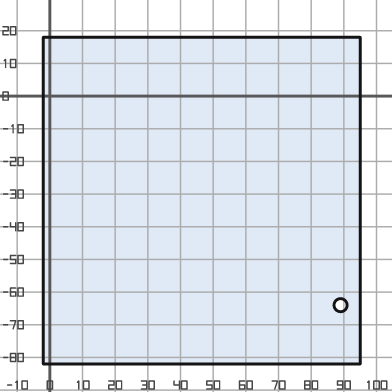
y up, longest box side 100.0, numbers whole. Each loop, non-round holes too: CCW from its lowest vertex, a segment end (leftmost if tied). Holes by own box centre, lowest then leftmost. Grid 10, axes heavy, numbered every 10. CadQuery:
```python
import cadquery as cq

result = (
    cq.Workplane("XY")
    .moveTo(-2.0, -82.0)
    .lineTo(95.0, -82.0)
    .lineTo(95.0, 18.0)
    .lineTo(-2.0, 18.0)
    .close()
    .moveTo(89.0, -64.0)
    .circle(2.0)
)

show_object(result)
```